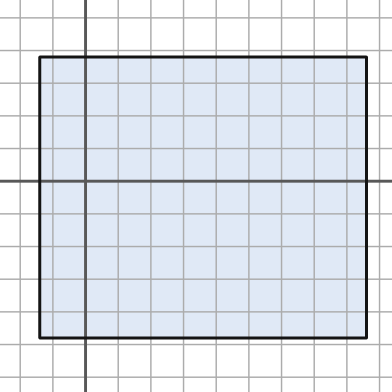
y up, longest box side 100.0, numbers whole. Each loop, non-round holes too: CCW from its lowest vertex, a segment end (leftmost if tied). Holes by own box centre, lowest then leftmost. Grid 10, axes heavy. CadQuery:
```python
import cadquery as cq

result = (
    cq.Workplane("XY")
    .moveTo(-14.0, -48.0)
    .lineTo(86.0, -48.0)
    .lineTo(86.0, 38.0)
    .lineTo(-14.0, 38.0)
    .close()
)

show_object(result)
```